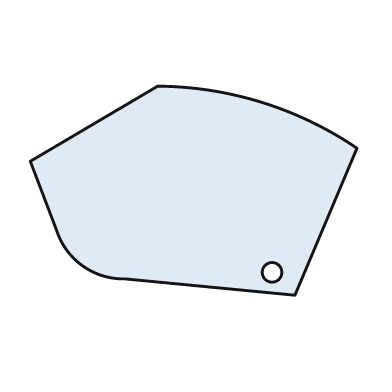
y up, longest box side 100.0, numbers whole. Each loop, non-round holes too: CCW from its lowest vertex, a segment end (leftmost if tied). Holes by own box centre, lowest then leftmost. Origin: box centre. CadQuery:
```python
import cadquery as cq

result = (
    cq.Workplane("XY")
    .moveTo(31.0, -32.0)
    .lineTo(50.0, 13.0)
    .threePointArc((21.0, 27.0), (-11.0, 32.0))
    .lineTo(-50.0, 9.0)
    .lineTo(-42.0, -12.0)
    .threePointArc((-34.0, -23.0), (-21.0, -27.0))
    .close()
    .moveTo(24.0, -25.0)
    .circle(3.0)
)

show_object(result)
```